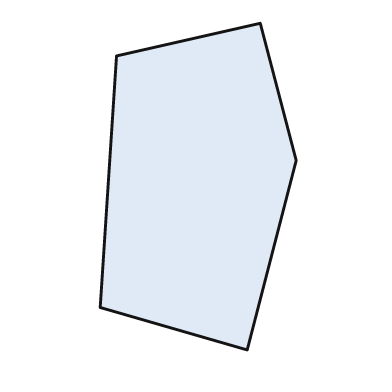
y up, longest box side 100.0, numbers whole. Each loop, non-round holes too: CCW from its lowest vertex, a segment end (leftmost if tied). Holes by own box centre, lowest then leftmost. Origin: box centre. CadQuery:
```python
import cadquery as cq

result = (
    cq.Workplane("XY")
    .moveTo(15.0, -50.0)
    .lineTo(30.0, 8.0)
    .lineTo(19.0, 50.0)
    .lineTo(-25.0, 40.0)
    .lineTo(-30.0, -37.0)
    .close()
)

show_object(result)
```